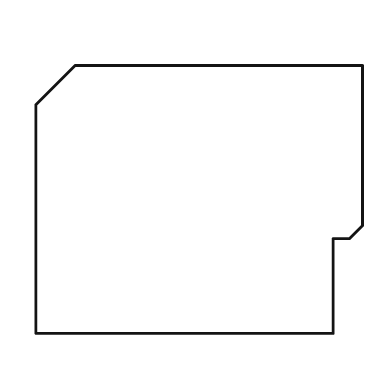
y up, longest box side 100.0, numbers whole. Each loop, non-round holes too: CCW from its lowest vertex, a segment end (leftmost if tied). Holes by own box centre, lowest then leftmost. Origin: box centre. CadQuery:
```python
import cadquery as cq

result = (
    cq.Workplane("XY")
    .moveTo(-50.0, -41.0)
    .lineTo(41.0, -41.0)
    .lineTo(41.0, -12.0)
    .lineTo(46.0, -12.0)
    .lineTo(50.0, -8.0)
    .lineTo(50.0, 41.0)
    .lineTo(-38.0, 41.0)
    .lineTo(-50.0, 29.0)
    .close()
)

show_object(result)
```